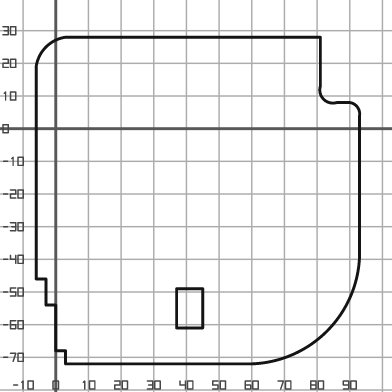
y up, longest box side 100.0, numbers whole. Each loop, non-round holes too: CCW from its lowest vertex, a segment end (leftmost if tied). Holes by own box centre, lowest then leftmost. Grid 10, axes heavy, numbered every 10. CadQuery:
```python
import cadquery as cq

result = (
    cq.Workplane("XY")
    .moveTo(3.0, -72.0)
    .lineTo(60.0, -72.0)
    .threePointArc((83.0, -62.0), (93.0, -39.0))
    .lineTo(93.0, 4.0)
    .threePointArc((92.0, 7.0), (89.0, 8.0))
    .lineTo(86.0, 8.0)
    .threePointArc((82.0, 9.0), (81.0, 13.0))
    .lineTo(81.0, 28.0)
    .lineTo(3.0, 28.0)
    .threePointArc((-3.0, 25.0), (-6.0, 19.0))
    .lineTo(-6.0, -46.0)
    .lineTo(-3.0, -46.0)
    .lineTo(-3.0, -54.0)
    .lineTo(0.0, -54.0)
    .lineTo(0.0, -68.0)
    .lineTo(3.0, -68.0)
    .close()
    .moveTo(37.0, -61.0)
    .lineTo(45.0, -61.0)
    .lineTo(45.0, -49.0)
    .lineTo(37.0, -49.0)
    .close()
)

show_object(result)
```